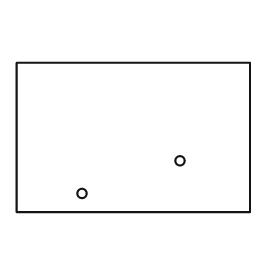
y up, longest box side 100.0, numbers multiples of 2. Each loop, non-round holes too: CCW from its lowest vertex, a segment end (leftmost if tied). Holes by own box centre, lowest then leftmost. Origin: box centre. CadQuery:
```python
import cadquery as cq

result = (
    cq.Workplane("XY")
    .moveTo(-50.0, -32.0)
    .lineTo(50.0, -32.0)
    .lineTo(50.0, 32.0)
    .lineTo(-50.0, 32.0)
    .close()
    .moveTo(-22.0, -24.0)
    .circle(2.0)
    .moveTo(20.0, -10.0)
    .circle(2.0)
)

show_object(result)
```